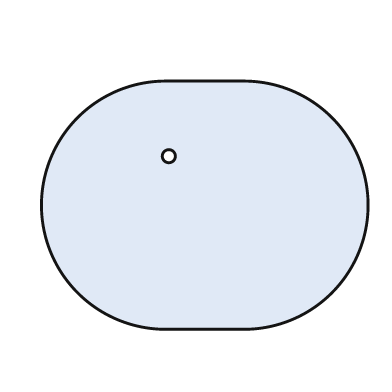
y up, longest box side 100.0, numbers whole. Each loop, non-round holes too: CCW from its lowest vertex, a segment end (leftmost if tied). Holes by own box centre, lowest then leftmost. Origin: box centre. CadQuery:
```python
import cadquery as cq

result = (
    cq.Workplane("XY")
    .moveTo(-12.0, -38.0)
    .lineTo(12.0, -38.0)
    .threePointArc((50.0, 0.0), (12.0, 38.0))
    .lineTo(-12.0, 38.0)
    .threePointArc((-50.0, 0.0), (-12.0, -38.0))
    .close()
    .moveTo(-11.0, 15.0)
    .circle(2.0)
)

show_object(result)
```